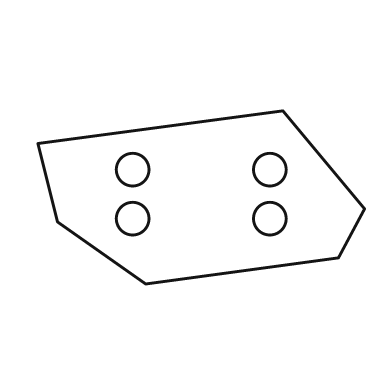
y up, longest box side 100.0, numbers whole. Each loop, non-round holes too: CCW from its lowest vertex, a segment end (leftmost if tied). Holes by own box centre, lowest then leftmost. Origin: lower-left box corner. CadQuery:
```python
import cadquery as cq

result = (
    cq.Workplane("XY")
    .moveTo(33.0, 0.0)
    .lineTo(92.0, 8.0)
    .lineTo(100.0, 23.0)
    .lineTo(75.0, 53.0)
    .lineTo(0.0, 43.0)
    .lineTo(6.0, 19.0)
    .close()
    .moveTo(29.0, 20.0)
    .circle(5.0)
    .moveTo(71.0, 20.0)
    .circle(5.0)
    .moveTo(29.0, 35.0)
    .circle(5.0)
    .moveTo(71.0, 35.0)
    .circle(5.0)
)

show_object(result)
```